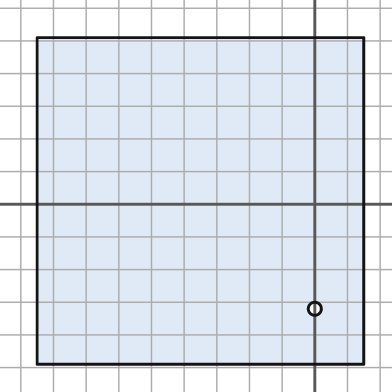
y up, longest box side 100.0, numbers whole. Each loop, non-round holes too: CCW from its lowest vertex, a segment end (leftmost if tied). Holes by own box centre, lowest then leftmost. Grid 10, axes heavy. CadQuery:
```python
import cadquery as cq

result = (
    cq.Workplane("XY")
    .moveTo(-85.0, -49.0)
    .lineTo(15.0, -49.0)
    .lineTo(15.0, 51.0)
    .lineTo(-85.0, 51.0)
    .close()
    .moveTo(0.0, -32.0)
    .circle(2.0)
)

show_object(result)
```